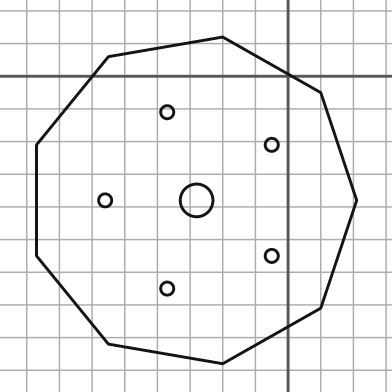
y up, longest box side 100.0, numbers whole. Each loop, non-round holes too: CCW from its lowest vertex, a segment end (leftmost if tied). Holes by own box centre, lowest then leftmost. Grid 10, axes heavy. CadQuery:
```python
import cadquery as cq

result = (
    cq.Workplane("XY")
    .moveTo(-20.0, -88.0)
    .lineTo(10.0, -71.0)
    .lineTo(21.0, -38.0)
    .lineTo(10.0, -5.0)
    .lineTo(-20.0, 12.0)
    .lineTo(-55.0, 6.0)
    .lineTo(-77.0, -21.0)
    .lineTo(-77.0, -55.0)
    .lineTo(-55.0, -82.0)
    .close()
    .moveTo(-37.0, -65.0)
    .circle(2.0)
    .moveTo(-5.0, -55.0)
    .circle(2.0)
    .moveTo(-56.0, -38.0)
    .circle(2.0)
    .moveTo(-28.0, -38.0)
    .circle(5.0)
    .moveTo(-5.0, -21.0)
    .circle(2.0)
    .moveTo(-37.0, -11.0)
    .circle(2.0)
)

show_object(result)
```